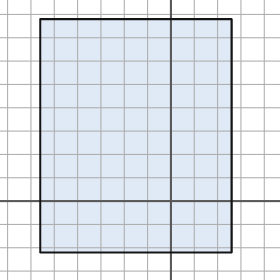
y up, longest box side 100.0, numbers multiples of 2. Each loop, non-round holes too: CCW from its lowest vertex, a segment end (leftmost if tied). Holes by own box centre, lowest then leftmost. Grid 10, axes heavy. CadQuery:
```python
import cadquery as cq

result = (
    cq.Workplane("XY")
    .moveTo(-56.0, -22.0)
    .lineTo(26.0, -22.0)
    .lineTo(26.0, 78.0)
    .lineTo(-56.0, 78.0)
    .close()
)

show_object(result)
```